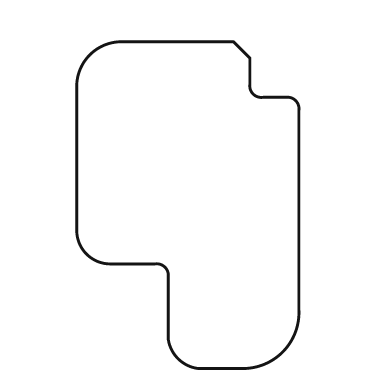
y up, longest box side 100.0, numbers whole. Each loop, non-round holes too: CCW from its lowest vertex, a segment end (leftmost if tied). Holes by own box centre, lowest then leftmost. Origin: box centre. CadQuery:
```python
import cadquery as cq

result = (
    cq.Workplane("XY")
    .moveTo(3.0, -50.0)
    .lineTo(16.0, -50.0)
    .threePointArc((29.0, -45.0), (34.0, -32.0))
    .lineTo(34.0, 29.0)
    .threePointArc((33.0, 32.0), (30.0, 33.0))
    .lineTo(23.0, 33.0)
    .threePointArc((20.0, 34.0), (19.0, 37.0))
    .lineTo(19.0, 45.0)
    .lineTo(14.0, 50.0)
    .lineTo(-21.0, 50.0)
    .threePointArc((-30.0, 46.0), (-34.0, 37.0))
    .lineTo(-34.0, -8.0)
    .threePointArc((-31.0, -15.0), (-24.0, -18.0))
    .lineTo(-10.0, -18.0)
    .threePointArc((-7.0, -19.0), (-6.0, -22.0))
    .lineTo(-6.0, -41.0)
    .threePointArc((-3.0, -47.0), (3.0, -50.0))
    .close()
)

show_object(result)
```